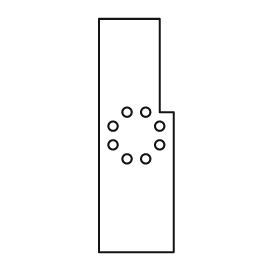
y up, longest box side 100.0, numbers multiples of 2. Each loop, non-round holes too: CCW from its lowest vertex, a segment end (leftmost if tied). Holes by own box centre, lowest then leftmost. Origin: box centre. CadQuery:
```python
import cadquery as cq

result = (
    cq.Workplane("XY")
    .moveTo(-16.0, -50.0)
    .lineTo(16.0, -50.0)
    .lineTo(16.0, 10.0)
    .lineTo(10.0, 10.0)
    .lineTo(10.0, 50.0)
    .lineTo(-16.0, 50.0)
    .close()
    .moveTo(-4.0, -10.0)
    .circle(2.0)
    .moveTo(4.0, -10.0)
    .circle(2.0)
    .moveTo(-10.0, -4.0)
    .circle(2.0)
    .moveTo(10.0, -4.0)
    .circle(2.0)
    .moveTo(-10.0, 4.0)
    .circle(2.0)
    .moveTo(10.0, 4.0)
    .circle(2.0)
    .moveTo(-4.0, 10.0)
    .circle(2.0)
    .moveTo(4.0, 10.0)
    .circle(2.0)
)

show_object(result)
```